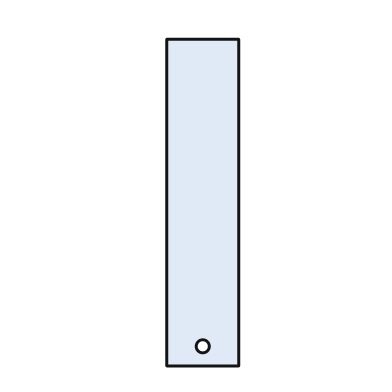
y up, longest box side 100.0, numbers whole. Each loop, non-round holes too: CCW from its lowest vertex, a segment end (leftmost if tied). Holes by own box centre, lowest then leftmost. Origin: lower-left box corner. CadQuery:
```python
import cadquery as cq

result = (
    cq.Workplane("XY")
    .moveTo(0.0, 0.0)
    .lineTo(22.0, 0.0)
    .lineTo(22.0, 100.0)
    .lineTo(0.0, 100.0)
    .close()
    .moveTo(11.0, 6.0)
    .circle(2.0)
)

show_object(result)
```